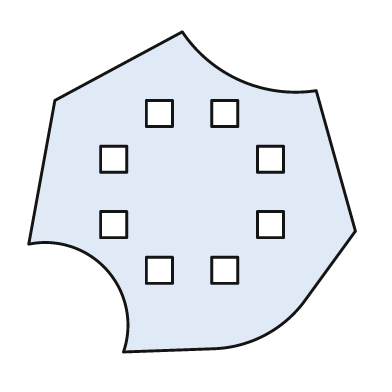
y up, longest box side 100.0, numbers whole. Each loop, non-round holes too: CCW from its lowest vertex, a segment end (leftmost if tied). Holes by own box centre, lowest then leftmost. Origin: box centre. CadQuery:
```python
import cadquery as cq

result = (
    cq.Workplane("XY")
    .moveTo(-21.0, -49.0)
    .lineTo(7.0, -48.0)
    .threePointArc((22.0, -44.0), (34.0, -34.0))
    .lineTo(50.0, -12.0)
    .lineTo(38.0, 31.0)
    .threePointArc((15.0, 34.0), (-3.0, 49.0))
    .lineTo(-42.0, 28.0)
    .lineTo(-50.0, -16.0)
    .threePointArc((-26.0, -24.0), (-21.0, -49.0))
    .close()
    .moveTo(-14.0, -28.0)
    .lineTo(-6.0, -28.0)
    .lineTo(-6.0, -20.0)
    .lineTo(-14.0, -20.0)
    .close()
    .moveTo(6.0, -28.0)
    .lineTo(14.0, -28.0)
    .lineTo(14.0, -20.0)
    .lineTo(6.0, -20.0)
    .close()
    .moveTo(-28.0, -14.0)
    .lineTo(-20.0, -14.0)
    .lineTo(-20.0, -6.0)
    .lineTo(-28.0, -6.0)
    .close()
    .moveTo(20.0, -14.0)
    .lineTo(28.0, -14.0)
    .lineTo(28.0, -6.0)
    .lineTo(20.0, -6.0)
    .close()
    .moveTo(-28.0, 6.0)
    .lineTo(-20.0, 6.0)
    .lineTo(-20.0, 14.0)
    .lineTo(-28.0, 14.0)
    .close()
    .moveTo(20.0, 6.0)
    .lineTo(28.0, 6.0)
    .lineTo(28.0, 14.0)
    .lineTo(20.0, 14.0)
    .close()
    .moveTo(-14.0, 20.0)
    .lineTo(-6.0, 20.0)
    .lineTo(-6.0, 28.0)
    .lineTo(-14.0, 28.0)
    .close()
    .moveTo(6.0, 20.0)
    .lineTo(14.0, 20.0)
    .lineTo(14.0, 28.0)
    .lineTo(6.0, 28.0)
    .close()
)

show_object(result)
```